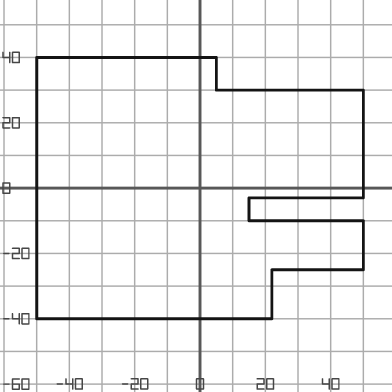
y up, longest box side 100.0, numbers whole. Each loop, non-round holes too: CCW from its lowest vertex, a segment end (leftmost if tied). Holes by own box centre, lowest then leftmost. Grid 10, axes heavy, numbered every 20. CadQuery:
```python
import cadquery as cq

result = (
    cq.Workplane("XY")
    .moveTo(-50.0, -40.0)
    .lineTo(22.0, -40.0)
    .lineTo(22.0, -25.0)
    .lineTo(50.0, -25.0)
    .lineTo(50.0, -10.0)
    .lineTo(15.0, -10.0)
    .lineTo(15.0, -3.0)
    .lineTo(50.0, -3.0)
    .lineTo(50.0, 30.0)
    .lineTo(5.0, 30.0)
    .lineTo(5.0, 40.0)
    .lineTo(-50.0, 40.0)
    .close()
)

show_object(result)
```